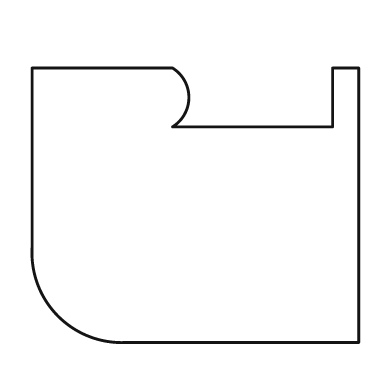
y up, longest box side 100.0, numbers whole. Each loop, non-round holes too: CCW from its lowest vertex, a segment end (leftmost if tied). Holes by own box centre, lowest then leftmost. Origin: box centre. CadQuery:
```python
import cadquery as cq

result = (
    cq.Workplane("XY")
    .moveTo(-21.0, -42.0)
    .lineTo(50.0, -42.0)
    .lineTo(50.0, 42.0)
    .lineTo(42.0, 42.0)
    .lineTo(42.0, 24.0)
    .lineTo(-7.0, 24.0)
    .threePointArc((-2.0, 33.0), (-7.0, 42.0))
    .lineTo(-50.0, 42.0)
    .lineTo(-50.0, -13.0)
    .threePointArc((-42.0, -34.0), (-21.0, -42.0))
    .close()
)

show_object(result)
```